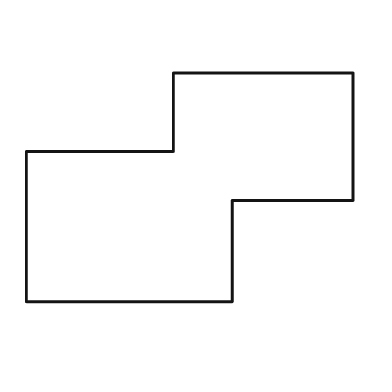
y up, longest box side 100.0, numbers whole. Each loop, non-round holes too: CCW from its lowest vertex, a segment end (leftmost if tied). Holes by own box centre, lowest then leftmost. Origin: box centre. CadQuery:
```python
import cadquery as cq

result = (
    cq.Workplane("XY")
    .moveTo(-50.0, -35.0)
    .lineTo(13.0, -35.0)
    .lineTo(13.0, -4.0)
    .lineTo(50.0, -4.0)
    .lineTo(50.0, 35.0)
    .lineTo(-5.0, 35.0)
    .lineTo(-5.0, 11.0)
    .lineTo(-50.0, 11.0)
    .close()
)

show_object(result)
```